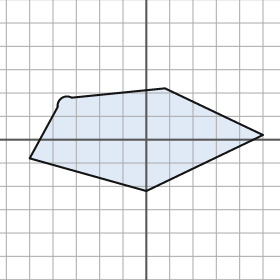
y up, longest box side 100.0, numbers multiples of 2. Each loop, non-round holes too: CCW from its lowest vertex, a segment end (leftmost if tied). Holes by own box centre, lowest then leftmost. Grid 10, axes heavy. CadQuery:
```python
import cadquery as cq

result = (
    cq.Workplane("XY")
    .moveTo(0.0, -22.0)
    .lineTo(50.0, 2.0)
    .lineTo(8.0, 22.0)
    .lineTo(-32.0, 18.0)
    .threePointArc((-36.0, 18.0), (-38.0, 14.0))
    .lineTo(-50.0, -8.0)
    .close()
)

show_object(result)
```